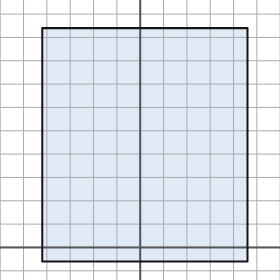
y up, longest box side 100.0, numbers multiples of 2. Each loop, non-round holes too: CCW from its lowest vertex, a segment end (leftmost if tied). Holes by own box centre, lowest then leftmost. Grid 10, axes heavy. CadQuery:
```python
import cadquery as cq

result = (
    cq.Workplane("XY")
    .moveTo(-42.0, -6.0)
    .lineTo(46.0, -6.0)
    .lineTo(46.0, 94.0)
    .lineTo(-42.0, 94.0)
    .close()
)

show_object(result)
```